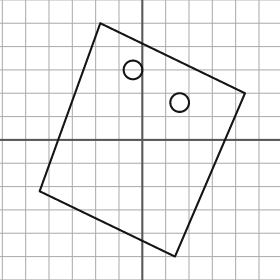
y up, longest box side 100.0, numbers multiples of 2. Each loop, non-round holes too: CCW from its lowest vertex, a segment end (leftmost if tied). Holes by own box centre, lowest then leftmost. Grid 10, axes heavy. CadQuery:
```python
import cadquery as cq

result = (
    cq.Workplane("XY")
    .moveTo(14.0, -50.0)
    .lineTo(44.0, 20.0)
    .lineTo(-18.0, 50.0)
    .lineTo(-44.0, -22.0)
    .close()
    .moveTo(16.0, 16.0)
    .circle(4.0)
    .moveTo(-4.0, 30.0)
    .circle(4.0)
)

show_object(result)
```